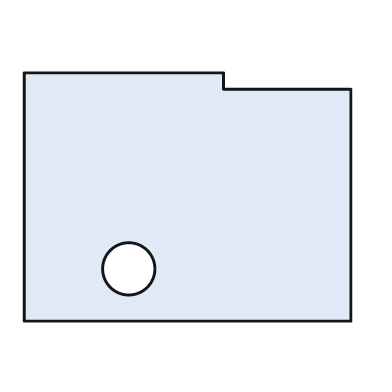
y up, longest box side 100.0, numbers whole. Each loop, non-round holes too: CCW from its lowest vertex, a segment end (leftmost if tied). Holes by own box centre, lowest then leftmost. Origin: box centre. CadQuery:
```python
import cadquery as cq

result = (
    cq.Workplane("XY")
    .moveTo(-50.0, -38.0)
    .lineTo(50.0, -38.0)
    .lineTo(50.0, 33.0)
    .lineTo(11.0, 33.0)
    .lineTo(11.0, 38.0)
    .lineTo(-50.0, 38.0)
    .close()
    .moveTo(-18.0, -22.0)
    .circle(8.0)
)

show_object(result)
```